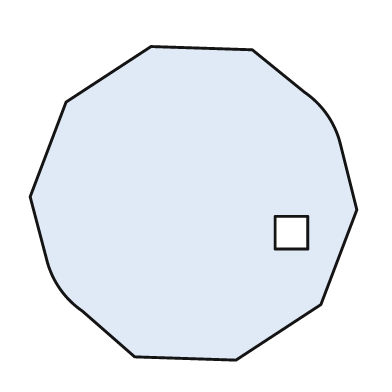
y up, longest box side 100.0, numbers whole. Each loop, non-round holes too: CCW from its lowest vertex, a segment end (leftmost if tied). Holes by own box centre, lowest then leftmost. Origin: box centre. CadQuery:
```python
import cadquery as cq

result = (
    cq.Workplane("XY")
    .moveTo(13.0, -48.0)
    .lineTo(39.0, -31.0)
    .lineTo(50.0, -2.0)
    .lineTo(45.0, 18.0)
    .threePointArc((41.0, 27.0), (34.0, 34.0))
    .lineTo(18.0, 47.0)
    .lineTo(-13.0, 48.0)
    .lineTo(-39.0, 31.0)
    .lineTo(-50.0, 2.0)
    .lineTo(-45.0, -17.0)
    .threePointArc((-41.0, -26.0), (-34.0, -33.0))
    .lineTo(-18.0, -47.0)
    .close()
    .moveTo(25.0, -14.0)
    .lineTo(35.0, -14.0)
    .lineTo(35.0, -4.0)
    .lineTo(25.0, -4.0)
    .close()
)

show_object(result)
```